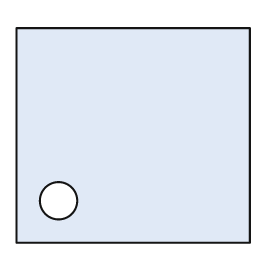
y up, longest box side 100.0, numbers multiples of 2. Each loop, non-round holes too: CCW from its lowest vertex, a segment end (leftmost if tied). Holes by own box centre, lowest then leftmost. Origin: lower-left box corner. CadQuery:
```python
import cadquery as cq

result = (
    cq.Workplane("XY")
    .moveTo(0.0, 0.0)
    .lineTo(100.0, 0.0)
    .lineTo(100.0, 92.0)
    .lineTo(0.0, 92.0)
    .close()
    .moveTo(18.0, 18.0)
    .circle(8.0)
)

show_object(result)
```